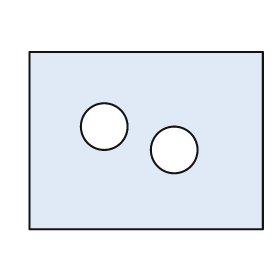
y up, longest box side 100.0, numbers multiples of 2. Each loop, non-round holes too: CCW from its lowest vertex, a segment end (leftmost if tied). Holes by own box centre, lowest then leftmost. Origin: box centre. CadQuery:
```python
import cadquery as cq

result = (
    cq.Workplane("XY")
    .moveTo(-50.0, -38.0)
    .lineTo(50.0, -38.0)
    .lineTo(50.0, 38.0)
    .lineTo(-50.0, 38.0)
    .close()
    .moveTo(12.0, -4.0)
    .circle(10.0)
    .moveTo(-18.0, 6.0)
    .circle(10.0)
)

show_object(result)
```